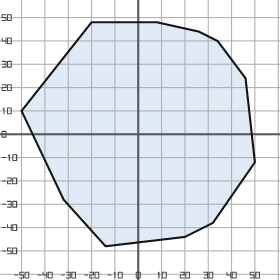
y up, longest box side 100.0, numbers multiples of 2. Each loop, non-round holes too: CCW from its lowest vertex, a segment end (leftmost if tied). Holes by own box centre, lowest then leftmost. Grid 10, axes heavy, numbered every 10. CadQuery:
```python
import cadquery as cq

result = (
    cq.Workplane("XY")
    .moveTo(-14.0, -48.0)
    .lineTo(20.0, -44.0)
    .lineTo(32.0, -38.0)
    .lineTo(50.0, -12.0)
    .lineTo(46.0, 24.0)
    .lineTo(34.0, 40.0)
    .lineTo(26.0, 44.0)
    .lineTo(8.0, 48.0)
    .lineTo(-20.0, 48.0)
    .lineTo(-50.0, 10.0)
    .lineTo(-32.0, -28.0)
    .close()
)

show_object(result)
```